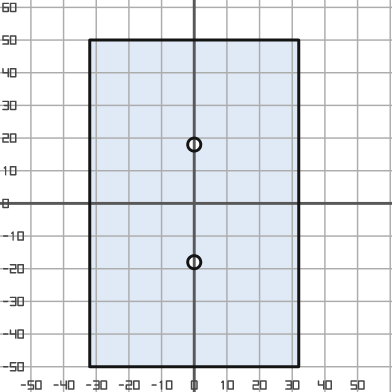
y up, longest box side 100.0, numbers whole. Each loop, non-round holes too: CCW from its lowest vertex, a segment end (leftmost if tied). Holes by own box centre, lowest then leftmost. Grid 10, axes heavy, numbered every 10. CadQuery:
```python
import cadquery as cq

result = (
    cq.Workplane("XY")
    .moveTo(-32.0, -50.0)
    .lineTo(32.0, -50.0)
    .lineTo(32.0, 50.0)
    .lineTo(-32.0, 50.0)
    .close()
    .moveTo(0.0, -18.0)
    .circle(2.0)
    .moveTo(0.0, 18.0)
    .circle(2.0)
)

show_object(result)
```